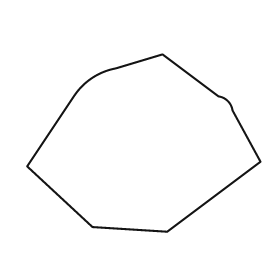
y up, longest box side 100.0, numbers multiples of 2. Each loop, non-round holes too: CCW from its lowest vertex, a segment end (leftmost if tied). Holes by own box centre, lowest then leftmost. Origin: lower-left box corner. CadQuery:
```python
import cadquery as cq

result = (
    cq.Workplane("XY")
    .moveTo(60.0, 0.0)
    .lineTo(100.0, 30.0)
    .lineTo(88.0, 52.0)
    .threePointArc((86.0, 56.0), (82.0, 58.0))
    .lineTo(58.0, 76.0)
    .lineTo(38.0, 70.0)
    .threePointArc((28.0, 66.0), (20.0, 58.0))
    .lineTo(0.0, 28.0)
    .lineTo(28.0, 2.0)
    .close()
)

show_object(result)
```